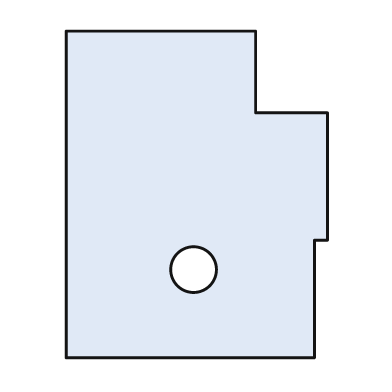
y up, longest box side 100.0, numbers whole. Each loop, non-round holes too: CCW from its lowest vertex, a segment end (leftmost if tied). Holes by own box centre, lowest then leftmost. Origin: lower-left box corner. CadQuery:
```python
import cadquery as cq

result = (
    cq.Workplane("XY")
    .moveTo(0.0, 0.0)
    .lineTo(76.0, 0.0)
    .lineTo(76.0, 36.0)
    .lineTo(80.0, 36.0)
    .lineTo(80.0, 75.0)
    .lineTo(58.0, 75.0)
    .lineTo(58.0, 100.0)
    .lineTo(0.0, 100.0)
    .close()
    .moveTo(39.0, 27.0)
    .circle(7.0)
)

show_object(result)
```